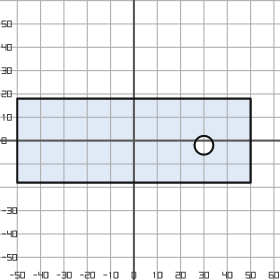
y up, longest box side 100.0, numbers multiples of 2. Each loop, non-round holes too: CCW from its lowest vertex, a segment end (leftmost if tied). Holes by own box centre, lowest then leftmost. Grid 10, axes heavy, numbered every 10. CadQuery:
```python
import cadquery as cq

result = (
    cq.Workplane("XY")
    .moveTo(-50.0, -18.0)
    .lineTo(50.0, -18.0)
    .lineTo(50.0, 18.0)
    .lineTo(-50.0, 18.0)
    .close()
    .moveTo(30.0, -2.0)
    .circle(4.0)
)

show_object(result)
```